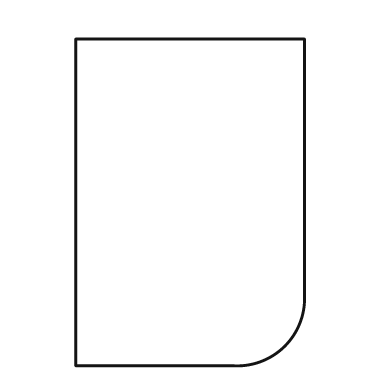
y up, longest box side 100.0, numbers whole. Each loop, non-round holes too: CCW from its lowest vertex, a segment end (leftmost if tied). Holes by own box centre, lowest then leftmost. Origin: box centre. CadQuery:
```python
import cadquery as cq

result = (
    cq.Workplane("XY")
    .moveTo(-35.0, -50.0)
    .lineTo(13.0, -50.0)
    .threePointArc((29.0, -44.0), (35.0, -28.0))
    .lineTo(35.0, 50.0)
    .lineTo(-35.0, 50.0)
    .close()
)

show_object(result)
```